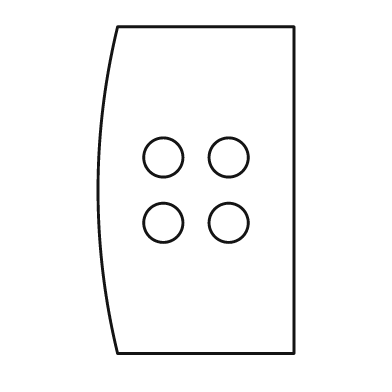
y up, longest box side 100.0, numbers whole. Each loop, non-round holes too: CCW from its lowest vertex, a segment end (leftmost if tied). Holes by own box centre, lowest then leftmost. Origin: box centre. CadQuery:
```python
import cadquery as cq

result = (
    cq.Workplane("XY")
    .moveTo(-24.0, -50.0)
    .lineTo(30.0, -50.0)
    .lineTo(30.0, 50.0)
    .lineTo(-24.0, 50.0)
    .threePointArc((-30.0, 0.0), (-24.0, -50.0))
    .close()
    .moveTo(-10.0, -10.0)
    .circle(6.0)
    .moveTo(10.0, -10.0)
    .circle(6.0)
    .moveTo(-10.0, 10.0)
    .circle(6.0)
    .moveTo(10.0, 10.0)
    .circle(6.0)
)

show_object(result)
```